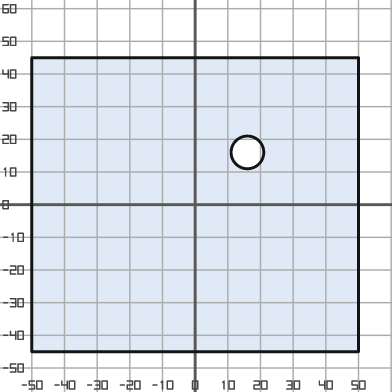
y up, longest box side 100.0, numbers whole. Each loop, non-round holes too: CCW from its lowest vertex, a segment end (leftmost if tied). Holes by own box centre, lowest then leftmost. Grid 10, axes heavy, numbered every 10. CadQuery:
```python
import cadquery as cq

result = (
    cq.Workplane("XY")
    .moveTo(-50.0, -45.0)
    .lineTo(50.0, -45.0)
    .lineTo(50.0, 45.0)
    .lineTo(-50.0, 45.0)
    .close()
    .moveTo(16.0, 16.0)
    .circle(5.0)
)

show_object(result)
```